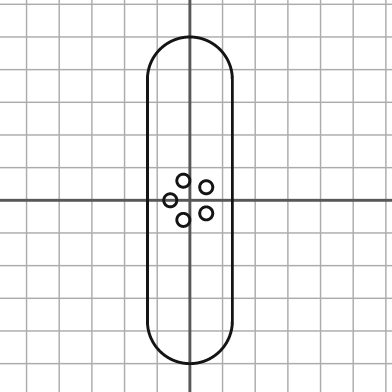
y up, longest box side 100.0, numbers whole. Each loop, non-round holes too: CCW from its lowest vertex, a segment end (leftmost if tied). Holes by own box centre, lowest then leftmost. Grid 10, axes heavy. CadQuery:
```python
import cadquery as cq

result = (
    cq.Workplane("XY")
    .moveTo(-13.0, -37.0)
    .threePointArc((0.0, -50.0), (13.0, -37.0))
    .lineTo(13.0, 37.0)
    .threePointArc((0.0, 50.0), (-13.0, 37.0))
    .close()
    .moveTo(-2.0, -6.0)
    .circle(2.0)
    .moveTo(5.0, -4.0)
    .circle(2.0)
    .moveTo(-6.0, 0.0)
    .circle(2.0)
    .moveTo(5.0, 4.0)
    .circle(2.0)
    .moveTo(-2.0, 6.0)
    .circle(2.0)
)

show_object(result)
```